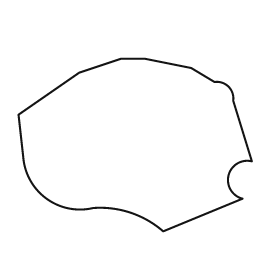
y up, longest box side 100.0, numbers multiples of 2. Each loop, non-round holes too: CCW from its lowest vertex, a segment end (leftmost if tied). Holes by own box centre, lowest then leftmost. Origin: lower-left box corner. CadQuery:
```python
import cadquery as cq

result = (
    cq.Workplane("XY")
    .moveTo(62.0, 0.0)
    .lineTo(96.0, 14.0)
    .threePointArc((90.0, 24.0), (100.0, 30.0))
    .lineTo(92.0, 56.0)
    .threePointArc((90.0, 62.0), (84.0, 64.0))
    .lineTo(74.0, 70.0)
    .lineTo(54.0, 74.0)
    .lineTo(44.0, 74.0)
    .lineTo(26.0, 68.0)
    .lineTo(0.0, 50.0)
    .lineTo(2.0, 32.0)
    .threePointArc((12.0, 14.0), (32.0, 10.0))
    .threePointArc((48.0, 8.0), (62.0, 0.0))
    .close()
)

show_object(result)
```